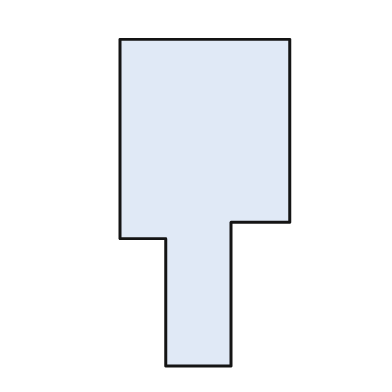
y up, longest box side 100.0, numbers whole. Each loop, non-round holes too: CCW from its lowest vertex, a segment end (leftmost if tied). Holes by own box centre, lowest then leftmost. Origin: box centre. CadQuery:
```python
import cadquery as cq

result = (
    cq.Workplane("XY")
    .moveTo(-12.0, -50.0)
    .lineTo(8.0, -50.0)
    .lineTo(8.0, -6.0)
    .lineTo(26.0, -6.0)
    .lineTo(26.0, 50.0)
    .lineTo(-26.0, 50.0)
    .lineTo(-26.0, -11.0)
    .lineTo(-12.0, -11.0)
    .close()
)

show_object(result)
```